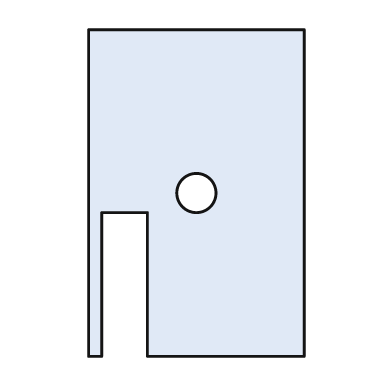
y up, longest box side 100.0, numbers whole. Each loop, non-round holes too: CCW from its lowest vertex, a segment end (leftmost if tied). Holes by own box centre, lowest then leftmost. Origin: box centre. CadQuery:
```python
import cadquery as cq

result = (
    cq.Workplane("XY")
    .moveTo(-33.0, -50.0)
    .lineTo(-29.0, -50.0)
    .lineTo(-29.0, -6.0)
    .lineTo(-15.0, -6.0)
    .lineTo(-15.0, -50.0)
    .lineTo(33.0, -50.0)
    .lineTo(33.0, 50.0)
    .lineTo(-33.0, 50.0)
    .close()
    .moveTo(0.0, 0.0)
    .circle(6.0)
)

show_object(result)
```